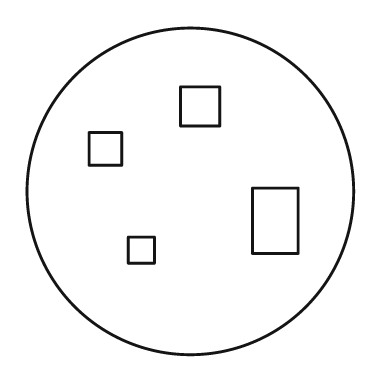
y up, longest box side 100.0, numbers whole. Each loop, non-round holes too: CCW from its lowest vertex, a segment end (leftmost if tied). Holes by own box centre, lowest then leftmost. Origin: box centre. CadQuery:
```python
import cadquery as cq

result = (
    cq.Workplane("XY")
    .moveTo(0.0, 0.0)
    .circle(50.0)
    .moveTo(-19.0, -22.0)
    .lineTo(-11.0, -22.0)
    .lineTo(-11.0, -14.0)
    .lineTo(-19.0, -14.0)
    .close()
    .moveTo(19.0, -19.0)
    .lineTo(33.0, -19.0)
    .lineTo(33.0, 1.0)
    .lineTo(19.0, 1.0)
    .close()
    .moveTo(-31.0, 8.0)
    .lineTo(-21.0, 8.0)
    .lineTo(-21.0, 18.0)
    .lineTo(-31.0, 18.0)
    .close()
    .moveTo(-3.0, 20.0)
    .lineTo(9.0, 20.0)
    .lineTo(9.0, 32.0)
    .lineTo(-3.0, 32.0)
    .close()
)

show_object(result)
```